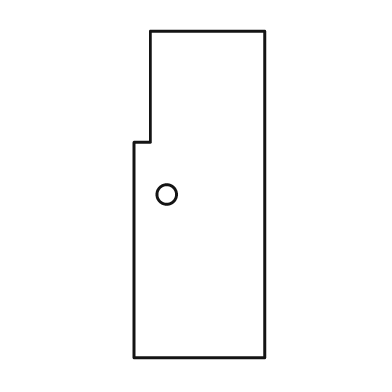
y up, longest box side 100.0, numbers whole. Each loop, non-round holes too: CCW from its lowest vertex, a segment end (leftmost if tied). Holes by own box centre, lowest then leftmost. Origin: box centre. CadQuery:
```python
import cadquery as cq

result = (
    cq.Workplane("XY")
    .moveTo(-20.0, -50.0)
    .lineTo(20.0, -50.0)
    .lineTo(20.0, 50.0)
    .lineTo(-15.0, 50.0)
    .lineTo(-15.0, 16.0)
    .lineTo(-20.0, 16.0)
    .close()
    .moveTo(-10.0, 0.0)
    .circle(3.0)
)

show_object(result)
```